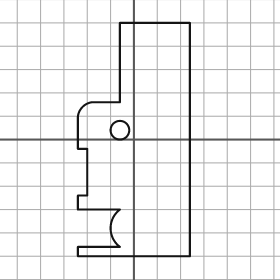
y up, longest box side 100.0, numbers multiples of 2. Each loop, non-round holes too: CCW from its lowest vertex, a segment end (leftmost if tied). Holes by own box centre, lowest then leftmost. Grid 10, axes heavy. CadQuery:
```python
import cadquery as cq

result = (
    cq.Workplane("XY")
    .moveTo(-24.0, -50.0)
    .lineTo(24.0, -50.0)
    .lineTo(24.0, 50.0)
    .lineTo(-6.0, 50.0)
    .lineTo(-6.0, 16.0)
    .lineTo(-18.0, 16.0)
    .threePointArc((-22.0, 14.0), (-24.0, 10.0))
    .lineTo(-24.0, -4.0)
    .lineTo(-20.0, -4.0)
    .lineTo(-20.0, -24.0)
    .lineTo(-24.0, -24.0)
    .lineTo(-24.0, -30.0)
    .lineTo(-6.0, -30.0)
    .threePointArc((-10.0, -38.0), (-6.0, -46.0))
    .lineTo(-24.0, -46.0)
    .close()
    .moveTo(-6.0, 4.0)
    .circle(4.0)
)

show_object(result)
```